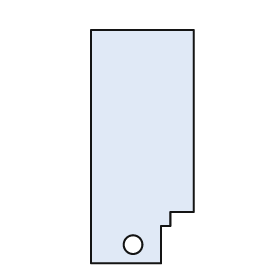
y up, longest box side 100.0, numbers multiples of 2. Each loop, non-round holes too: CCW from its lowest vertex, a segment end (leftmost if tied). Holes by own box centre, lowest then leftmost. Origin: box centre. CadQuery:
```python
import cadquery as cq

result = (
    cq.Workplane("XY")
    .moveTo(-22.0, -50.0)
    .lineTo(8.0, -50.0)
    .lineTo(8.0, -34.0)
    .lineTo(12.0, -34.0)
    .lineTo(12.0, -28.0)
    .lineTo(22.0, -28.0)
    .lineTo(22.0, 50.0)
    .lineTo(-22.0, 50.0)
    .close()
    .moveTo(-4.0, -42.0)
    .circle(4.0)
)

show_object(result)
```